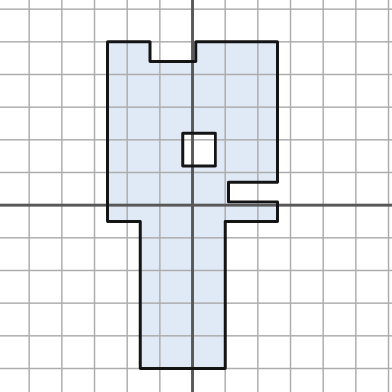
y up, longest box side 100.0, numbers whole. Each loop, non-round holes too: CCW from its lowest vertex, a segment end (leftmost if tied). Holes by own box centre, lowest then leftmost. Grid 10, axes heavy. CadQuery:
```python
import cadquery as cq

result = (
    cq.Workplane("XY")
    .moveTo(-16.0, -50.0)
    .lineTo(10.0, -50.0)
    .lineTo(10.0, -5.0)
    .lineTo(26.0, -5.0)
    .lineTo(26.0, 1.0)
    .lineTo(11.0, 1.0)
    .lineTo(11.0, 7.0)
    .lineTo(26.0, 7.0)
    .lineTo(26.0, 50.0)
    .lineTo(1.0, 50.0)
    .lineTo(1.0, 44.0)
    .lineTo(-13.0, 44.0)
    .lineTo(-13.0, 50.0)
    .lineTo(-26.0, 50.0)
    .lineTo(-26.0, -5.0)
    .lineTo(-16.0, -5.0)
    .close()
    .moveTo(-3.0, 12.0)
    .lineTo(7.0, 12.0)
    .lineTo(7.0, 22.0)
    .lineTo(-3.0, 22.0)
    .close()
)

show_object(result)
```